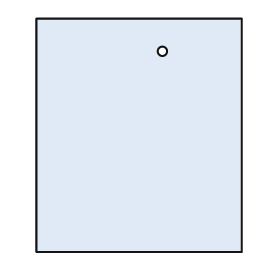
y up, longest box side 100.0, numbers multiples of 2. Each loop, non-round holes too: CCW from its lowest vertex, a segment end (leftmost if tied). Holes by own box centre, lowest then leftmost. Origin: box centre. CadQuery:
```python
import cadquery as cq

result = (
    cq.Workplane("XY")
    .moveTo(-44.0, -50.0)
    .lineTo(44.0, -50.0)
    .lineTo(44.0, 50.0)
    .lineTo(-44.0, 50.0)
    .close()
    .moveTo(10.0, 36.0)
    .circle(2.0)
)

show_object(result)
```